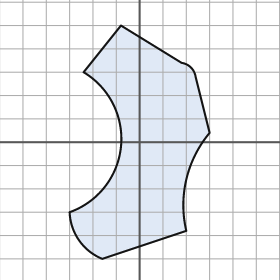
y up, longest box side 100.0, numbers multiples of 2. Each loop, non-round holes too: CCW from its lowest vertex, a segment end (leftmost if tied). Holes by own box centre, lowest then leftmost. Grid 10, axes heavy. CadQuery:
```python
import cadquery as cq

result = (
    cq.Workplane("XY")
    .moveTo(-16.0, -50.0)
    .lineTo(20.0, -38.0)
    .threePointArc((20.0, -16.0), (30.0, 4.0))
    .lineTo(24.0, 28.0)
    .threePointArc((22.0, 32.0), (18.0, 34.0))
    .lineTo(-8.0, 50.0)
    .lineTo(-24.0, 30.0)
    .threePointArc((-8.0, -2.0), (-30.0, -30.0))
    .threePointArc((-26.0, -42.0), (-16.0, -50.0))
    .close()
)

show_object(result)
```